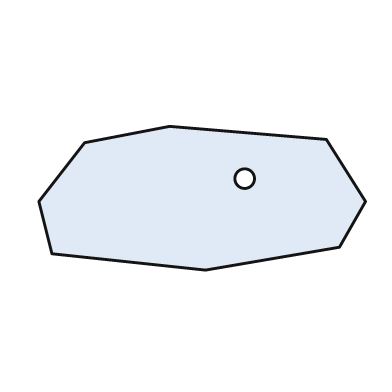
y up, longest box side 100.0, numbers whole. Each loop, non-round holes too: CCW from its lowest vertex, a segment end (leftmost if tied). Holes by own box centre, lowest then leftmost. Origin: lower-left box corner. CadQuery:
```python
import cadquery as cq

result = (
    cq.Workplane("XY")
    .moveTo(51.0, 0.0)
    .lineTo(92.0, 7.0)
    .lineTo(100.0, 21.0)
    .lineTo(88.0, 40.0)
    .lineTo(40.0, 44.0)
    .lineTo(14.0, 39.0)
    .lineTo(0.0, 21.0)
    .lineTo(4.0, 5.0)
    .close()
    .moveTo(63.0, 28.0)
    .circle(3.0)
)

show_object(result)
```